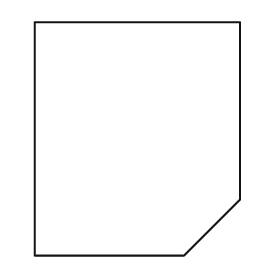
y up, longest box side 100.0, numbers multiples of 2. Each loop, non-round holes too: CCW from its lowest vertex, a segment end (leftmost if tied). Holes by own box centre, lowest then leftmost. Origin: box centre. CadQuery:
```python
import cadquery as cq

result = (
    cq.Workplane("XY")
    .moveTo(-44.0, -50.0)
    .lineTo(20.0, -50.0)
    .lineTo(44.0, -26.0)
    .lineTo(44.0, 50.0)
    .lineTo(-44.0, 50.0)
    .close()
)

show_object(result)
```